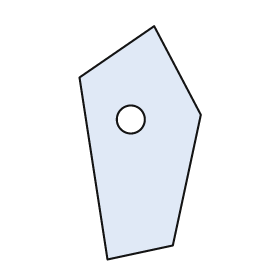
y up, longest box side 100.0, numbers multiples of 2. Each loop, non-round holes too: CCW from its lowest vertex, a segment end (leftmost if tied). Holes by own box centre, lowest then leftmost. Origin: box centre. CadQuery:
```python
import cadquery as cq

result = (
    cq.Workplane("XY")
    .moveTo(-14.0, -50.0)
    .lineTo(14.0, -44.0)
    .lineTo(26.0, 12.0)
    .lineTo(6.0, 50.0)
    .lineTo(-26.0, 28.0)
    .close()
    .moveTo(-4.0, 10.0)
    .circle(6.0)
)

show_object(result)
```